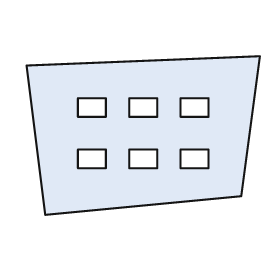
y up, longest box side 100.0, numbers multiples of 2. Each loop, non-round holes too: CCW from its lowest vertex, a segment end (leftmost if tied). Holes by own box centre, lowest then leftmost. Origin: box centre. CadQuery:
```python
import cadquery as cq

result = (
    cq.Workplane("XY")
    .moveTo(-42.0, -34.0)
    .lineTo(42.0, -26.0)
    .lineTo(50.0, 34.0)
    .lineTo(-50.0, 30.0)
    .close()
    .moveTo(-28.0, -14.0)
    .lineTo(-16.0, -14.0)
    .lineTo(-16.0, -6.0)
    .lineTo(-28.0, -6.0)
    .close()
    .moveTo(-6.0, -14.0)
    .lineTo(6.0, -14.0)
    .lineTo(6.0, -6.0)
    .lineTo(-6.0, -6.0)
    .close()
    .moveTo(16.0, -14.0)
    .lineTo(28.0, -14.0)
    .lineTo(28.0, -6.0)
    .lineTo(16.0, -6.0)
    .close()
    .moveTo(-28.0, 8.0)
    .lineTo(-16.0, 8.0)
    .lineTo(-16.0, 16.0)
    .lineTo(-28.0, 16.0)
    .close()
    .moveTo(-6.0, 8.0)
    .lineTo(6.0, 8.0)
    .lineTo(6.0, 16.0)
    .lineTo(-6.0, 16.0)
    .close()
    .moveTo(16.0, 8.0)
    .lineTo(28.0, 8.0)
    .lineTo(28.0, 16.0)
    .lineTo(16.0, 16.0)
    .close()
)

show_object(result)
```